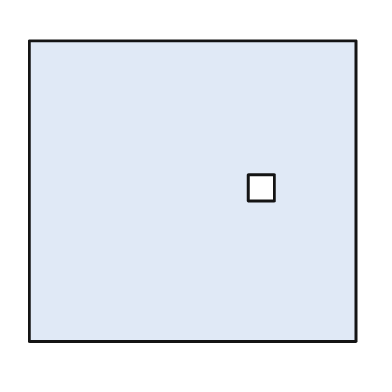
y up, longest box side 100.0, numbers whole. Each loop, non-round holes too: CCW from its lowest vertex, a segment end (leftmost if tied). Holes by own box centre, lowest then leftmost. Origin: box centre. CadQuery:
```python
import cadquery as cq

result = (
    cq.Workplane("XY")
    .moveTo(-50.0, -46.0)
    .lineTo(50.0, -46.0)
    .lineTo(50.0, 46.0)
    .lineTo(-50.0, 46.0)
    .close()
    .moveTo(17.0, -3.0)
    .lineTo(25.0, -3.0)
    .lineTo(25.0, 5.0)
    .lineTo(17.0, 5.0)
    .close()
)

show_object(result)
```